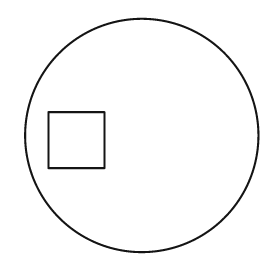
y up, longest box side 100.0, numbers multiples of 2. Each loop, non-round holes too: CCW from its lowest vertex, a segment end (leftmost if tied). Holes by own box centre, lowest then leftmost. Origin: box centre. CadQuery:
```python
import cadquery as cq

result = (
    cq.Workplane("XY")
    .moveTo(0.0, 0.0)
    .circle(50.0)
    .moveTo(-40.0, -14.0)
    .lineTo(-16.0, -14.0)
    .lineTo(-16.0, 10.0)
    .lineTo(-40.0, 10.0)
    .close()
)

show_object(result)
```